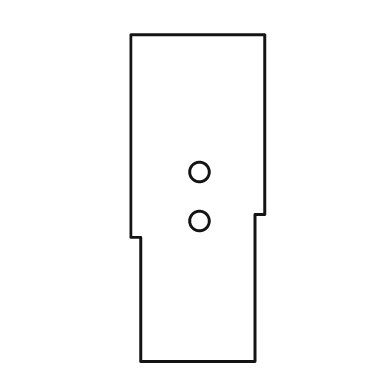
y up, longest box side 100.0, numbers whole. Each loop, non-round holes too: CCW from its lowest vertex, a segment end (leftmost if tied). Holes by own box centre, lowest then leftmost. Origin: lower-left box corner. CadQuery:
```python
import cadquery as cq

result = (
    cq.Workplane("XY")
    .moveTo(3.0, 0.0)
    .lineTo(38.0, 0.0)
    .lineTo(38.0, 45.0)
    .lineTo(41.0, 45.0)
    .lineTo(41.0, 100.0)
    .lineTo(0.0, 100.0)
    .lineTo(0.0, 38.0)
    .lineTo(3.0, 38.0)
    .close()
    .moveTo(21.0, 43.0)
    .circle(3.0)
    .moveTo(21.0, 58.0)
    .circle(3.0)
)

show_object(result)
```